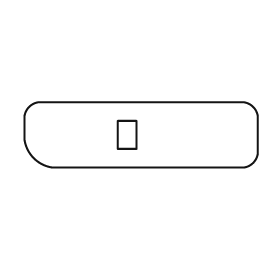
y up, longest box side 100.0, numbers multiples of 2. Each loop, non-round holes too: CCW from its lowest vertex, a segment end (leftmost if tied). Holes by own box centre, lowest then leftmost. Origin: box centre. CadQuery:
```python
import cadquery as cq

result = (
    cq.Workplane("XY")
    .moveTo(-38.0, -14.0)
    .lineTo(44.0, -14.0)
    .threePointArc((48.0, -12.0), (50.0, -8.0))
    .lineTo(50.0, 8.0)
    .threePointArc((48.0, 12.0), (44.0, 14.0))
    .lineTo(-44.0, 14.0)
    .threePointArc((-48.0, 12.0), (-50.0, 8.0))
    .lineTo(-50.0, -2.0)
    .threePointArc((-46.0, -10.0), (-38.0, -14.0))
    .close()
    .moveTo(-10.0, -6.0)
    .lineTo(-2.0, -6.0)
    .lineTo(-2.0, 6.0)
    .lineTo(-10.0, 6.0)
    .close()
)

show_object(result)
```